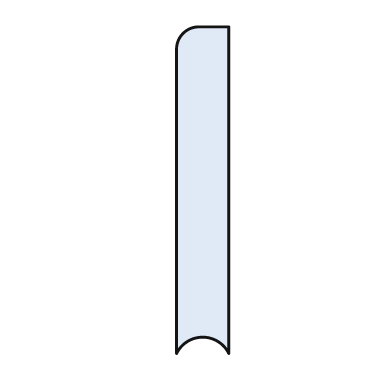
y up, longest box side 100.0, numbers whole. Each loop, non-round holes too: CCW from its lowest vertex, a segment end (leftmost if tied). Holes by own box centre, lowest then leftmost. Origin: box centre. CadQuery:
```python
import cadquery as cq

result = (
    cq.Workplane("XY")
    .moveTo(-8.0, -50.0)
    .threePointArc((0.0, -45.0), (8.0, -50.0))
    .lineTo(8.0, 50.0)
    .lineTo(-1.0, 50.0)
    .threePointArc((-6.0, 48.0), (-8.0, 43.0))
    .close()
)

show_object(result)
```